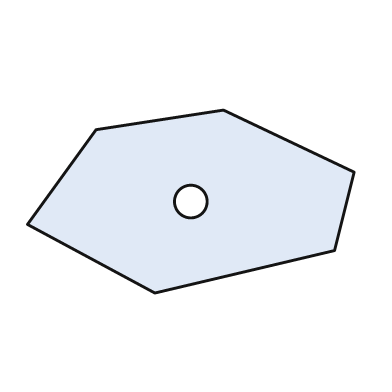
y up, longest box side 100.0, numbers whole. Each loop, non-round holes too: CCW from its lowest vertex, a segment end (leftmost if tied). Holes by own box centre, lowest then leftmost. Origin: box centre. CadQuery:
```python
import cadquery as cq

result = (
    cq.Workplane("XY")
    .moveTo(-11.0, -28.0)
    .lineTo(44.0, -15.0)
    .lineTo(50.0, 9.0)
    .lineTo(10.0, 28.0)
    .lineTo(-29.0, 22.0)
    .lineTo(-50.0, -7.0)
    .close()
    .moveTo(0.0, 0.0)
    .circle(5.0)
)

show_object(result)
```